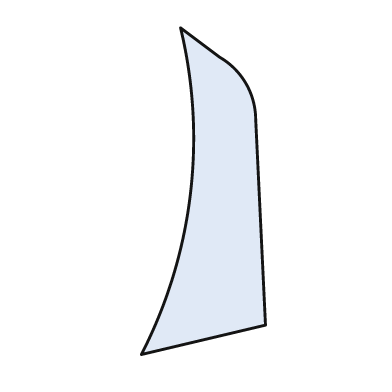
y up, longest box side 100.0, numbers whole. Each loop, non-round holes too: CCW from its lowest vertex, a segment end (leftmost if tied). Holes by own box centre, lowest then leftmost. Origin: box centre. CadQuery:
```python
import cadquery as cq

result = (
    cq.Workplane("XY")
    .moveTo(-19.0, -50.0)
    .lineTo(19.0, -41.0)
    .lineTo(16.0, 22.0)
    .threePointArc((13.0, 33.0), (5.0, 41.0))
    .lineTo(-7.0, 50.0)
    .threePointArc((-4.0, -1.0), (-19.0, -50.0))
    .close()
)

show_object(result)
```